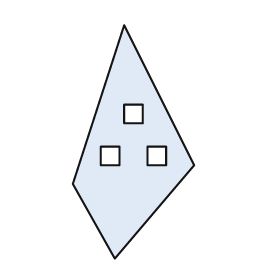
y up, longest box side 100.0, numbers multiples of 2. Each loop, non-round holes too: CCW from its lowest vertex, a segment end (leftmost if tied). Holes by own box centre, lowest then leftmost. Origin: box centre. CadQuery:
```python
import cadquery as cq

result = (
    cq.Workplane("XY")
    .moveTo(-8.0, -50.0)
    .lineTo(26.0, -10.0)
    .lineTo(-4.0, 50.0)
    .lineTo(-26.0, -18.0)
    .close()
    .moveTo(-14.0, -10.0)
    .lineTo(-6.0, -10.0)
    .lineTo(-6.0, -2.0)
    .lineTo(-14.0, -2.0)
    .close()
    .moveTo(6.0, -10.0)
    .lineTo(14.0, -10.0)
    .lineTo(14.0, -2.0)
    .lineTo(6.0, -2.0)
    .close()
    .moveTo(-4.0, 8.0)
    .lineTo(4.0, 8.0)
    .lineTo(4.0, 16.0)
    .lineTo(-4.0, 16.0)
    .close()
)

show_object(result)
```